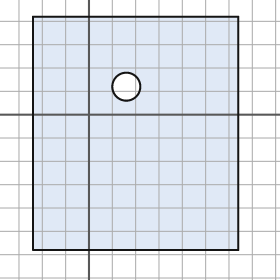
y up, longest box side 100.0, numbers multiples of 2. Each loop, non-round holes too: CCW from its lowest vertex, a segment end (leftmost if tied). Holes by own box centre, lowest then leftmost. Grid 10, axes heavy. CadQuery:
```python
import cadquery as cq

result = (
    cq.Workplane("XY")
    .moveTo(-24.0, -58.0)
    .lineTo(64.0, -58.0)
    .lineTo(64.0, 42.0)
    .lineTo(-24.0, 42.0)
    .close()
    .moveTo(16.0, 12.0)
    .circle(6.0)
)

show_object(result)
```